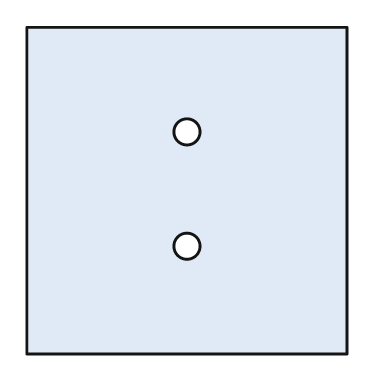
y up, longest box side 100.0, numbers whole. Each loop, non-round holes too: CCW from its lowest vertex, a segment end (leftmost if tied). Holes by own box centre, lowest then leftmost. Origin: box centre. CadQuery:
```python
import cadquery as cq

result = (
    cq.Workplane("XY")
    .moveTo(-49.0, -50.0)
    .lineTo(49.0, -50.0)
    .lineTo(49.0, 50.0)
    .lineTo(-49.0, 50.0)
    .close()
    .moveTo(0.0, -17.0)
    .circle(4.0)
    .moveTo(0.0, 18.0)
    .circle(4.0)
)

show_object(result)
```